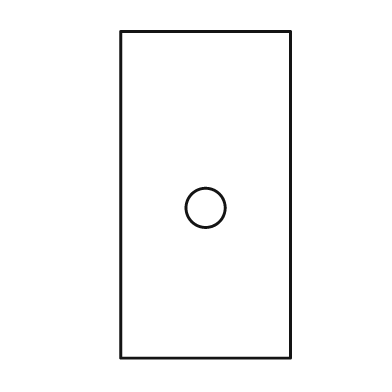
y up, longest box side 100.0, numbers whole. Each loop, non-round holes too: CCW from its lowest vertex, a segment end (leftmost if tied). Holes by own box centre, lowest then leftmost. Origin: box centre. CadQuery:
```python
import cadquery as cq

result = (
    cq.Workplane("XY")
    .moveTo(-26.0, -50.0)
    .lineTo(26.0, -50.0)
    .lineTo(26.0, 50.0)
    .lineTo(-26.0, 50.0)
    .close()
    .moveTo(0.0, -4.0)
    .circle(6.0)
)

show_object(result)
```